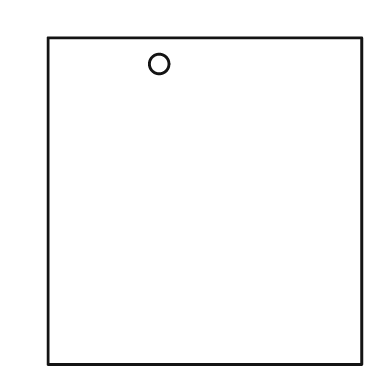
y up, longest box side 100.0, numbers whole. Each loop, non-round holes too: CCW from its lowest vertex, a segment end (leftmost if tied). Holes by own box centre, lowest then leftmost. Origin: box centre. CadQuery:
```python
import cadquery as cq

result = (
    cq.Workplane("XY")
    .moveTo(-48.0, -50.0)
    .lineTo(48.0, -50.0)
    .lineTo(48.0, 50.0)
    .lineTo(-48.0, 50.0)
    .close()
    .moveTo(-14.0, 42.0)
    .circle(3.0)
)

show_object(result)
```